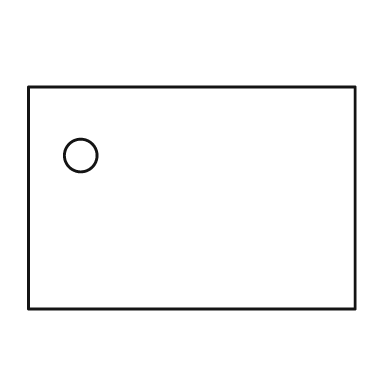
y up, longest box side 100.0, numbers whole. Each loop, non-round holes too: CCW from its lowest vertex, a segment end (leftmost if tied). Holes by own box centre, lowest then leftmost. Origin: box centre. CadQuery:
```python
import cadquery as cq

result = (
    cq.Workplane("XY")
    .moveTo(-50.0, -34.0)
    .lineTo(50.0, -34.0)
    .lineTo(50.0, 34.0)
    .lineTo(-50.0, 34.0)
    .close()
    .moveTo(-34.0, 13.0)
    .circle(5.0)
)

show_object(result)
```